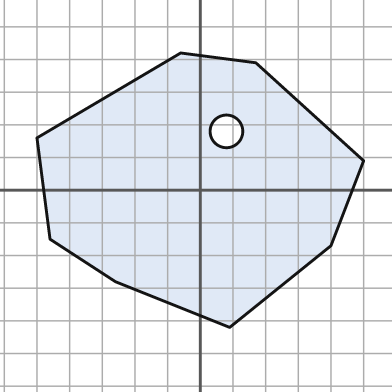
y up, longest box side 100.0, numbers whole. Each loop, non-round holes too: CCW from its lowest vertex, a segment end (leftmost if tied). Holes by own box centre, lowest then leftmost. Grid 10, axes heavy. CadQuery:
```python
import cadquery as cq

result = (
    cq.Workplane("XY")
    .moveTo(9.0, -42.0)
    .lineTo(40.0, -17.0)
    .lineTo(50.0, 9.0)
    .lineTo(17.0, 39.0)
    .lineTo(-6.0, 42.0)
    .lineTo(-50.0, 16.0)
    .lineTo(-46.0, -15.0)
    .lineTo(-26.0, -28.0)
    .close()
    .moveTo(8.0, 18.0)
    .circle(5.0)
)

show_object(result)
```